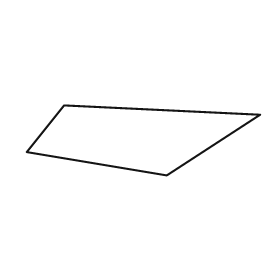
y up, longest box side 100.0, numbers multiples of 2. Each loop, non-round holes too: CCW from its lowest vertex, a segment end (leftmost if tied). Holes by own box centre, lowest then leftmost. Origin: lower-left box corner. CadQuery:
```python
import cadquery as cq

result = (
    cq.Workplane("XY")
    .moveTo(60.0, 0.0)
    .lineTo(100.0, 26.0)
    .lineTo(16.0, 30.0)
    .lineTo(0.0, 10.0)
    .close()
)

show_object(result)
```